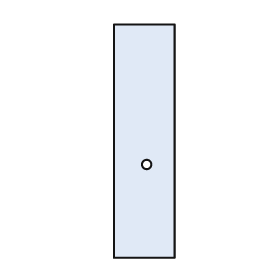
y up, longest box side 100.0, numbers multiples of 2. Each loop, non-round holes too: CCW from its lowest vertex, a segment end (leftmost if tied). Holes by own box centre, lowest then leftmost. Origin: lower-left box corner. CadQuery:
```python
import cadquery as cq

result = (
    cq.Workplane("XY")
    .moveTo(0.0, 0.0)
    .lineTo(26.0, 0.0)
    .lineTo(26.0, 100.0)
    .lineTo(0.0, 100.0)
    .close()
    .moveTo(14.0, 40.0)
    .circle(2.0)
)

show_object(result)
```